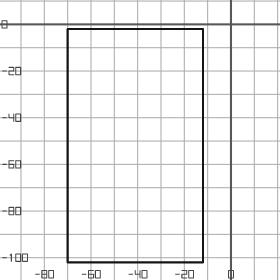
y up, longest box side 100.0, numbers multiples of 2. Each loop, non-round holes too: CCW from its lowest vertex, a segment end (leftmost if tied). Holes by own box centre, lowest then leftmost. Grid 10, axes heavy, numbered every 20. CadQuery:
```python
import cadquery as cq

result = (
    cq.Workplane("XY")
    .moveTo(-70.0, -102.0)
    .lineTo(-12.0, -102.0)
    .lineTo(-12.0, -2.0)
    .lineTo(-70.0, -2.0)
    .close()
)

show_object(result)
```